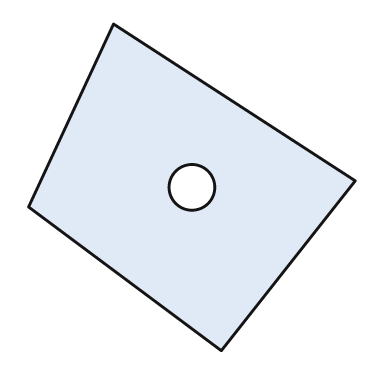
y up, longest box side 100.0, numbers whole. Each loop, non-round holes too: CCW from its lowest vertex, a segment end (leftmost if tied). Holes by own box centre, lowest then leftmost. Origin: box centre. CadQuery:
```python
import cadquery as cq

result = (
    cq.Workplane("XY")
    .moveTo(9.0, -50.0)
    .lineTo(50.0, 2.0)
    .lineTo(-24.0, 50.0)
    .lineTo(-50.0, -6.0)
    .close()
    .moveTo(0.0, 0.0)
    .circle(7.0)
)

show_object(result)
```